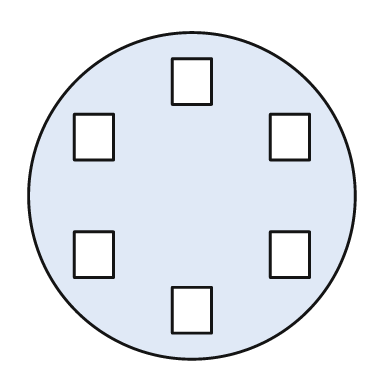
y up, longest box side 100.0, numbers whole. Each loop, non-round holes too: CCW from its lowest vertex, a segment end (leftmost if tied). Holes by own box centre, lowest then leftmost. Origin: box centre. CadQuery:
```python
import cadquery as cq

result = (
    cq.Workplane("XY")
    .moveTo(0.0, 0.0)
    .circle(50.0)
    .moveTo(-6.0, -42.0)
    .lineTo(6.0, -42.0)
    .lineTo(6.0, -28.0)
    .lineTo(-6.0, -28.0)
    .close()
    .moveTo(-36.0, -25.0)
    .lineTo(-24.0, -25.0)
    .lineTo(-24.0, -11.0)
    .lineTo(-36.0, -11.0)
    .close()
    .moveTo(24.0, -25.0)
    .lineTo(36.0, -25.0)
    .lineTo(36.0, -11.0)
    .lineTo(24.0, -11.0)
    .close()
    .moveTo(-36.0, 11.0)
    .lineTo(-24.0, 11.0)
    .lineTo(-24.0, 25.0)
    .lineTo(-36.0, 25.0)
    .close()
    .moveTo(24.0, 11.0)
    .lineTo(36.0, 11.0)
    .lineTo(36.0, 25.0)
    .lineTo(24.0, 25.0)
    .close()
    .moveTo(-6.0, 28.0)
    .lineTo(6.0, 28.0)
    .lineTo(6.0, 42.0)
    .lineTo(-6.0, 42.0)
    .close()
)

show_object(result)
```